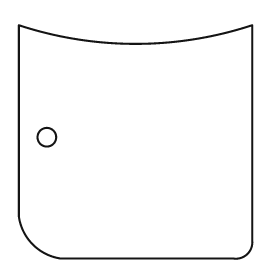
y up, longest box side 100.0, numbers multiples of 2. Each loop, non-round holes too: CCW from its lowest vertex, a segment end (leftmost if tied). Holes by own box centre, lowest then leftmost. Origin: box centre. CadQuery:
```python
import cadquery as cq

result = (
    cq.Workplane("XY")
    .moveTo(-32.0, -50.0)
    .lineTo(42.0, -50.0)
    .threePointArc((48.0, -48.0), (50.0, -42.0))
    .lineTo(50.0, 50.0)
    .threePointArc((0.0, 42.0), (-50.0, 50.0))
    .lineTo(-50.0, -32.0)
    .threePointArc((-44.0, -44.0), (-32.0, -50.0))
    .close()
    .moveTo(-38.0, 2.0)
    .circle(4.0)
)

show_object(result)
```